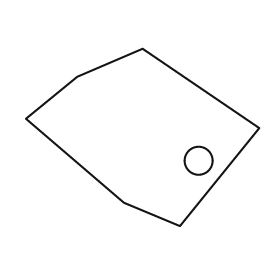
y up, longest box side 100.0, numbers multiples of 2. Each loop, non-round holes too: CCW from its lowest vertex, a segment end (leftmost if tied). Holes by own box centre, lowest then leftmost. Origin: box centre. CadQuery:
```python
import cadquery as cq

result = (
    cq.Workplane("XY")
    .moveTo(16.0, -38.0)
    .lineTo(50.0, 4.0)
    .lineTo(0.0, 38.0)
    .lineTo(-28.0, 26.0)
    .lineTo(-50.0, 8.0)
    .lineTo(-8.0, -28.0)
    .close()
    .moveTo(24.0, -10.0)
    .circle(6.0)
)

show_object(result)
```